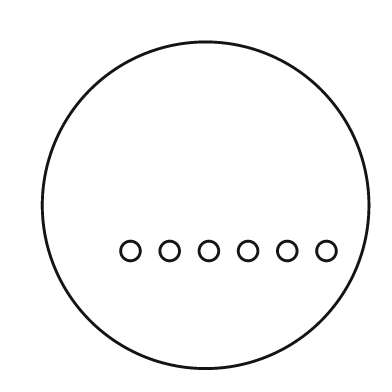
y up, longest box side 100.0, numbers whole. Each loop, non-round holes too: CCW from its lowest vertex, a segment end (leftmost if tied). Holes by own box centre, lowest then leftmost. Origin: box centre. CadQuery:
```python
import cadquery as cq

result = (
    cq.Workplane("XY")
    .moveTo(0.0, 0.0)
    .circle(50.0)
    .moveTo(-23.0, -14.0)
    .circle(3.0)
    .moveTo(-11.0, -14.0)
    .circle(3.0)
    .moveTo(1.0, -14.0)
    .circle(3.0)
    .moveTo(13.0, -14.0)
    .circle(3.0)
    .moveTo(25.0, -14.0)
    .circle(3.0)
    .moveTo(37.0, -14.0)
    .circle(3.0)
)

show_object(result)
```